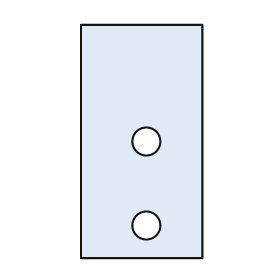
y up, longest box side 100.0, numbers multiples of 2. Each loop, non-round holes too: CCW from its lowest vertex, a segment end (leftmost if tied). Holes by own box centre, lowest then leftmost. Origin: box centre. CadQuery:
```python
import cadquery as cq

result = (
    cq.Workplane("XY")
    .moveTo(-26.0, -50.0)
    .lineTo(26.0, -50.0)
    .lineTo(26.0, 50.0)
    .lineTo(-26.0, 50.0)
    .close()
    .moveTo(2.0, -36.0)
    .circle(6.0)
    .moveTo(2.0, 0.0)
    .circle(6.0)
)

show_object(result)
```